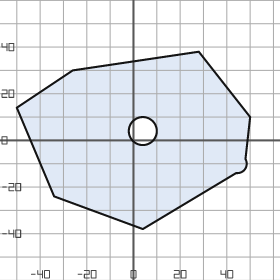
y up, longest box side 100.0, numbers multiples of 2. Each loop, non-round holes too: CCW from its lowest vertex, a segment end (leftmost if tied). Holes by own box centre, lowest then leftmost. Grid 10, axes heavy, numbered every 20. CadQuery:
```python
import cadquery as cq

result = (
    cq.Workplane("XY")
    .moveTo(4.0, -38.0)
    .lineTo(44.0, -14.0)
    .threePointArc((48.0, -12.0), (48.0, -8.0))
    .lineTo(50.0, 10.0)
    .lineTo(28.0, 38.0)
    .lineTo(-26.0, 30.0)
    .lineTo(-50.0, 14.0)
    .lineTo(-34.0, -24.0)
    .close()
    .moveTo(4.0, 4.0)
    .circle(6.0)
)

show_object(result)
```